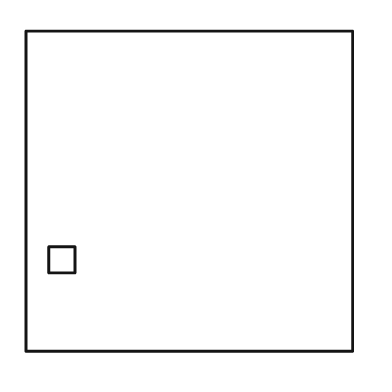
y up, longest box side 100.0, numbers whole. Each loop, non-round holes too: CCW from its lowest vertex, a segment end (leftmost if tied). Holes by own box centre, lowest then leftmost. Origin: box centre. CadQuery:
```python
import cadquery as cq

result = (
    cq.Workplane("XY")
    .moveTo(-50.0, -49.0)
    .lineTo(50.0, -49.0)
    .lineTo(50.0, 49.0)
    .lineTo(-50.0, 49.0)
    .close()
    .moveTo(-43.0, -25.0)
    .lineTo(-35.0, -25.0)
    .lineTo(-35.0, -17.0)
    .lineTo(-43.0, -17.0)
    .close()
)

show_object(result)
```